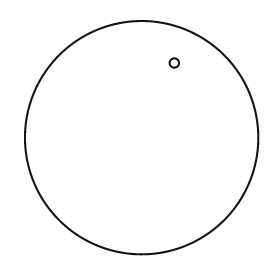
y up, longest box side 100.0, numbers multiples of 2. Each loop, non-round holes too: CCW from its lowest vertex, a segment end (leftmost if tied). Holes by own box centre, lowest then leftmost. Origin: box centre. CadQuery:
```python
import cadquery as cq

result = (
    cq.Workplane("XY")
    .moveTo(0.0, 0.0)
    .circle(50.0)
    .moveTo(14.0, 32.0)
    .circle(2.0)
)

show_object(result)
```